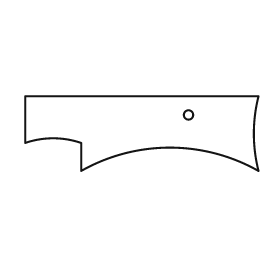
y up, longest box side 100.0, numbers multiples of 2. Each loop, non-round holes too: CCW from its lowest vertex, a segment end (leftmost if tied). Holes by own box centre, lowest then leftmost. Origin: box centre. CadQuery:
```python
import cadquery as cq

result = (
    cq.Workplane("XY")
    .moveTo(-26.0, -16.0)
    .threePointArc((12.0, -6.0), (50.0, -16.0))
    .threePointArc((48.0, 0.0), (50.0, 16.0))
    .lineTo(-50.0, 16.0)
    .lineTo(-50.0, -4.0)
    .threePointArc((-38.0, -2.0), (-26.0, -4.0))
    .close()
    .moveTo(20.0, 8.0)
    .circle(2.0)
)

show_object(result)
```